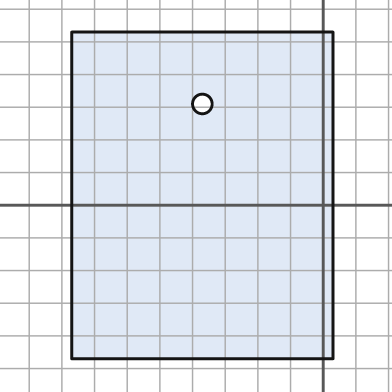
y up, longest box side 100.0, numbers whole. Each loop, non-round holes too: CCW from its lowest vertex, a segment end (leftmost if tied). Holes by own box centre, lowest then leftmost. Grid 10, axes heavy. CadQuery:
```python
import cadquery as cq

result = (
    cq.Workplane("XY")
    .moveTo(-77.0, -47.0)
    .lineTo(3.0, -47.0)
    .lineTo(3.0, 53.0)
    .lineTo(-77.0, 53.0)
    .close()
    .moveTo(-37.0, 31.0)
    .circle(3.0)
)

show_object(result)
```